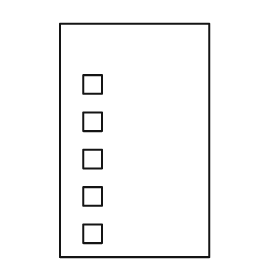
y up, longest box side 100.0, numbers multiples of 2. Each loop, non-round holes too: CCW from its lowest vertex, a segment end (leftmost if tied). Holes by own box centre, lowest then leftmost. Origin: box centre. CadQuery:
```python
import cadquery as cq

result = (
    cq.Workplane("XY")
    .moveTo(-32.0, -50.0)
    .lineTo(32.0, -50.0)
    .lineTo(32.0, 50.0)
    .lineTo(-32.0, 50.0)
    .close()
    .moveTo(-22.0, -44.0)
    .lineTo(-14.0, -44.0)
    .lineTo(-14.0, -36.0)
    .lineTo(-22.0, -36.0)
    .close()
    .moveTo(-22.0, -28.0)
    .lineTo(-14.0, -28.0)
    .lineTo(-14.0, -20.0)
    .lineTo(-22.0, -20.0)
    .close()
    .moveTo(-22.0, -12.0)
    .lineTo(-14.0, -12.0)
    .lineTo(-14.0, -4.0)
    .lineTo(-22.0, -4.0)
    .close()
    .moveTo(-22.0, 4.0)
    .lineTo(-14.0, 4.0)
    .lineTo(-14.0, 12.0)
    .lineTo(-22.0, 12.0)
    .close()
    .moveTo(-22.0, 20.0)
    .lineTo(-14.0, 20.0)
    .lineTo(-14.0, 28.0)
    .lineTo(-22.0, 28.0)
    .close()
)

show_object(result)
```